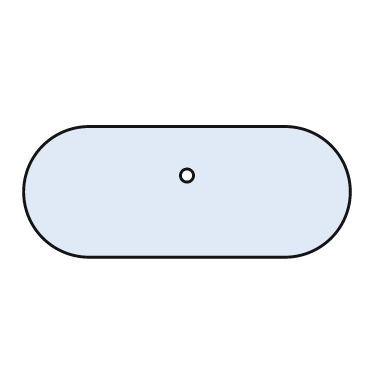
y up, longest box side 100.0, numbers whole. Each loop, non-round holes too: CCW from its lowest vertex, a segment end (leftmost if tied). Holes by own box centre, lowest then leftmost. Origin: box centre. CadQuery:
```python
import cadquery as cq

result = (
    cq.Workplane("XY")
    .moveTo(-30.0, -20.0)
    .lineTo(30.0, -20.0)
    .threePointArc((50.0, 0.0), (30.0, 20.0))
    .lineTo(-30.0, 20.0)
    .threePointArc((-50.0, 0.0), (-30.0, -20.0))
    .close()
    .moveTo(0.0, 5.0)
    .circle(2.0)
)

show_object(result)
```